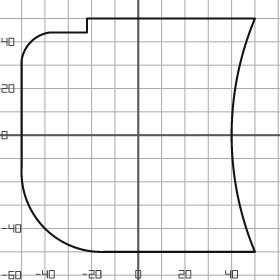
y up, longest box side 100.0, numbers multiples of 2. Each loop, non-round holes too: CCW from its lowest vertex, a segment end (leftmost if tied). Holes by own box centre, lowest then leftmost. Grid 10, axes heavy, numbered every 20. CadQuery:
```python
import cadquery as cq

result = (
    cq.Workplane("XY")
    .moveTo(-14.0, -50.0)
    .lineTo(50.0, -50.0)
    .threePointArc((40.0, 0.0), (50.0, 50.0))
    .lineTo(-22.0, 50.0)
    .lineTo(-22.0, 44.0)
    .lineTo(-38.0, 44.0)
    .threePointArc((-46.0, 40.0), (-50.0, 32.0))
    .lineTo(-50.0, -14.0)
    .threePointArc((-40.0, -40.0), (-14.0, -50.0))
    .close()
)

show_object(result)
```